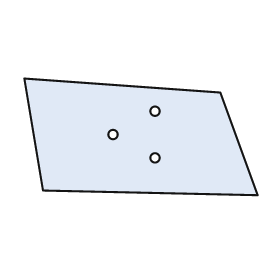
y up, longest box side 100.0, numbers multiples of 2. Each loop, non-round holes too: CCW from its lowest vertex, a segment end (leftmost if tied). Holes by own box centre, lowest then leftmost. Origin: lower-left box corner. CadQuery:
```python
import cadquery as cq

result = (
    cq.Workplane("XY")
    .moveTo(100.0, 0.0)
    .lineTo(84.0, 44.0)
    .lineTo(0.0, 50.0)
    .lineTo(8.0, 2.0)
    .close()
    .moveTo(56.0, 16.0)
    .circle(2.0)
    .moveTo(38.0, 26.0)
    .circle(2.0)
    .moveTo(56.0, 36.0)
    .circle(2.0)
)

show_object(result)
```